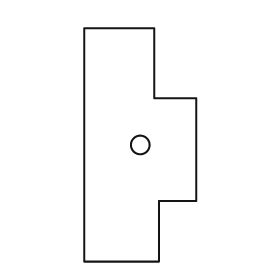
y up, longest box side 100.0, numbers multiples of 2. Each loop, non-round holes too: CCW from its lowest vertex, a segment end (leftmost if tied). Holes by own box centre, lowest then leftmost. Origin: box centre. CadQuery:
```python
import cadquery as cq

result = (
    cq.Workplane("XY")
    .moveTo(-24.0, -50.0)
    .lineTo(8.0, -50.0)
    .lineTo(8.0, -24.0)
    .lineTo(24.0, -24.0)
    .lineTo(24.0, 20.0)
    .lineTo(6.0, 20.0)
    .lineTo(6.0, 50.0)
    .lineTo(-24.0, 50.0)
    .close()
    .moveTo(0.0, 0.0)
    .circle(4.0)
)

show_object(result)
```